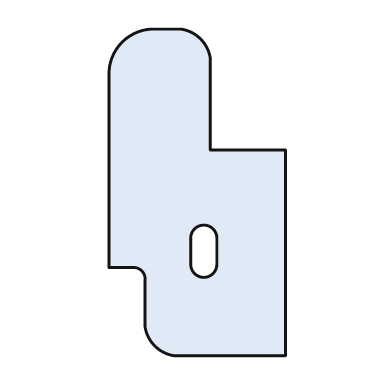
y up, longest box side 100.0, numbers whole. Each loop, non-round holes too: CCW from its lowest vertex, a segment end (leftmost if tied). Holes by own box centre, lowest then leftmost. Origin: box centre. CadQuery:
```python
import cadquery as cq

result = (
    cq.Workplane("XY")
    .moveTo(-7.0, -50.0)
    .lineTo(27.0, -50.0)
    .lineTo(27.0, 13.0)
    .lineTo(4.0, 13.0)
    .lineTo(4.0, 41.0)
    .threePointArc((1.0, 47.0), (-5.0, 50.0))
    .lineTo(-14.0, 50.0)
    .threePointArc((-23.0, 46.0), (-27.0, 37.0))
    .lineTo(-27.0, -23.0)
    .lineTo(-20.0, -23.0)
    .threePointArc((-17.0, -24.0), (-16.0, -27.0))
    .lineTo(-16.0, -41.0)
    .threePointArc((-13.0, -47.0), (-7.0, -50.0))
    .close()
    .moveTo(-2.0, -22.0)
    .threePointArc((2.0, -26.0), (6.0, -22.0))
    .lineTo(6.0, -14.0)
    .threePointArc((2.0, -10.0), (-2.0, -14.0))
    .close()
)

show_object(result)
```